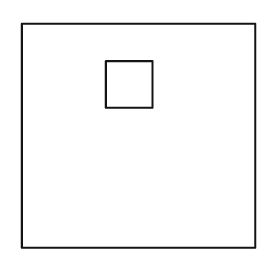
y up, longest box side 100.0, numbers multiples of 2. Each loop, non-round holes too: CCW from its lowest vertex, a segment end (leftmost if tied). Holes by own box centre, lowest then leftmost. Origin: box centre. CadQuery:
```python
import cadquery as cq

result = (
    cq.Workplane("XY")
    .moveTo(-50.0, -48.0)
    .lineTo(50.0, -48.0)
    .lineTo(50.0, 48.0)
    .lineTo(-50.0, 48.0)
    .close()
    .moveTo(-14.0, 12.0)
    .lineTo(6.0, 12.0)
    .lineTo(6.0, 32.0)
    .lineTo(-14.0, 32.0)
    .close()
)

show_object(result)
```